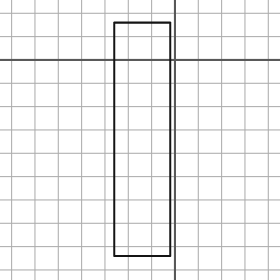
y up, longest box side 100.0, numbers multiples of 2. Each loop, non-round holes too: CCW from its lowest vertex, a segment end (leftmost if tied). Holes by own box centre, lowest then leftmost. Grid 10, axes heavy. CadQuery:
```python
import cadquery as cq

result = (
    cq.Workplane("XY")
    .moveTo(-26.0, -84.0)
    .lineTo(-2.0, -84.0)
    .lineTo(-2.0, 16.0)
    .lineTo(-26.0, 16.0)
    .close()
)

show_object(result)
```